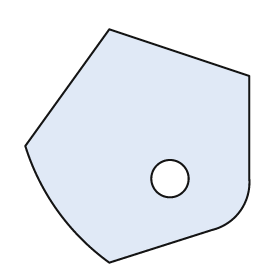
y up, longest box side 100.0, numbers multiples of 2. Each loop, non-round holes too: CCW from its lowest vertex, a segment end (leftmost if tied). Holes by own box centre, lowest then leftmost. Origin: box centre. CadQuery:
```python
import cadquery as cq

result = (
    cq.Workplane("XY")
    .moveTo(-12.0, -50.0)
    .lineTo(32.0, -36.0)
    .threePointArc((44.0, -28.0), (48.0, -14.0))
    .lineTo(48.0, 30.0)
    .lineTo(-12.0, 50.0)
    .lineTo(-48.0, 0.0)
    .threePointArc((-34.0, -28.0), (-12.0, -50.0))
    .close()
    .moveTo(14.0, -14.0)
    .circle(8.0)
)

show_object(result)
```